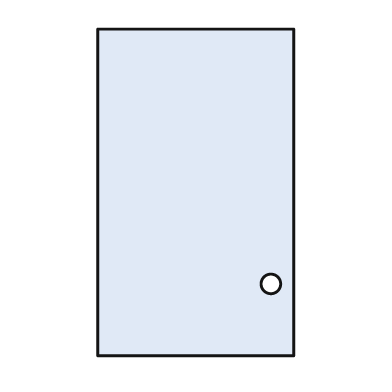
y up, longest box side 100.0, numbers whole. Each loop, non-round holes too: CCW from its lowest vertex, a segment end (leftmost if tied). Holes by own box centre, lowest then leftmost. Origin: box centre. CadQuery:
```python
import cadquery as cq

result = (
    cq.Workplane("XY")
    .moveTo(-30.0, -50.0)
    .lineTo(30.0, -50.0)
    .lineTo(30.0, 50.0)
    .lineTo(-30.0, 50.0)
    .close()
    .moveTo(23.0, -28.0)
    .circle(3.0)
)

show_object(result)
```